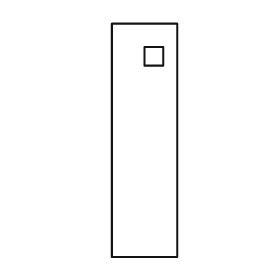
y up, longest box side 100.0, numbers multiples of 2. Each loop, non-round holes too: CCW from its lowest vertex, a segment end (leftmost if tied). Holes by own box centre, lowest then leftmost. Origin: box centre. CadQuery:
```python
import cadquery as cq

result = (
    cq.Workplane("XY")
    .moveTo(-14.0, -50.0)
    .lineTo(14.0, -50.0)
    .lineTo(14.0, 50.0)
    .lineTo(-14.0, 50.0)
    .close()
    .moveTo(0.0, 32.0)
    .lineTo(8.0, 32.0)
    .lineTo(8.0, 40.0)
    .lineTo(0.0, 40.0)
    .close()
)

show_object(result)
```